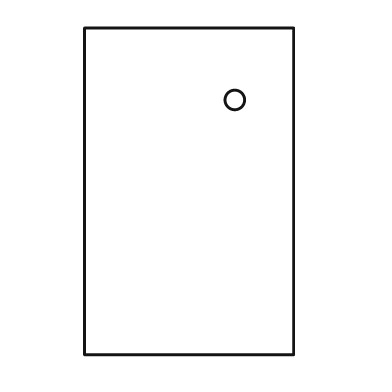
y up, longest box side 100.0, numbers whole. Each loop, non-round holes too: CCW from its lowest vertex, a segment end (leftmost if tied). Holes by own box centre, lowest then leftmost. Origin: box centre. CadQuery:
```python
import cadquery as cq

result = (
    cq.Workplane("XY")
    .moveTo(-32.0, -50.0)
    .lineTo(32.0, -50.0)
    .lineTo(32.0, 50.0)
    .lineTo(-32.0, 50.0)
    .close()
    .moveTo(14.0, 28.0)
    .circle(3.0)
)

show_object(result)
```